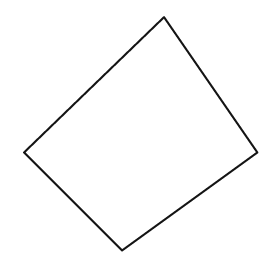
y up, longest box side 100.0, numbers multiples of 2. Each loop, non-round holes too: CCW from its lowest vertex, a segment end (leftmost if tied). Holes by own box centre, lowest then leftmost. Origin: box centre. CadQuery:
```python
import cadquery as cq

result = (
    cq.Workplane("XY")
    .moveTo(-8.0, -50.0)
    .lineTo(50.0, -8.0)
    .lineTo(10.0, 50.0)
    .lineTo(-50.0, -8.0)
    .close()
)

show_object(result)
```